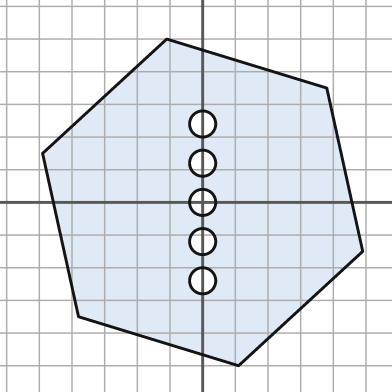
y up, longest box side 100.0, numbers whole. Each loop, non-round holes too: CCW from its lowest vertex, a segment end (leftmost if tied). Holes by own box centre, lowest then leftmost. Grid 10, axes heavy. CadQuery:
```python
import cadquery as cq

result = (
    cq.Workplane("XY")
    .moveTo(11.0, -50.0)
    .lineTo(49.0, -15.0)
    .lineTo(38.0, 35.0)
    .lineTo(-11.0, 50.0)
    .lineTo(-49.0, 15.0)
    .lineTo(-38.0, -35.0)
    .close()
    .moveTo(0.0, -24.0)
    .circle(4.0)
    .moveTo(0.0, -12.0)
    .circle(4.0)
    .moveTo(0.0, 0.0)
    .circle(4.0)
    .moveTo(0.0, 12.0)
    .circle(4.0)
    .moveTo(0.0, 24.0)
    .circle(4.0)
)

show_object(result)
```